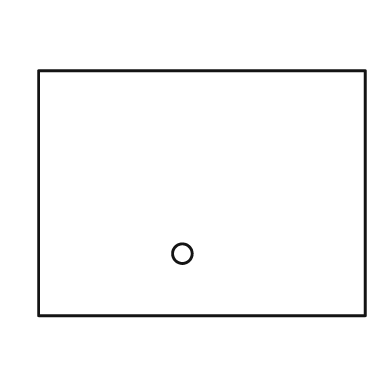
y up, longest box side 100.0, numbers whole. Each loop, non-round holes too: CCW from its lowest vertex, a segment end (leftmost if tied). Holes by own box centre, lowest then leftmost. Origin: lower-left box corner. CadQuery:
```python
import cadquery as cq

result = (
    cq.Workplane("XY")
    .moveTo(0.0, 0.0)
    .lineTo(100.0, 0.0)
    .lineTo(100.0, 75.0)
    .lineTo(0.0, 75.0)
    .close()
    .moveTo(44.0, 19.0)
    .circle(3.0)
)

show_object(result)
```